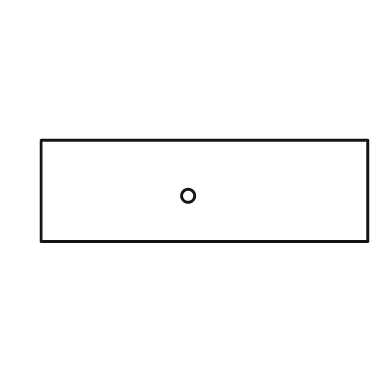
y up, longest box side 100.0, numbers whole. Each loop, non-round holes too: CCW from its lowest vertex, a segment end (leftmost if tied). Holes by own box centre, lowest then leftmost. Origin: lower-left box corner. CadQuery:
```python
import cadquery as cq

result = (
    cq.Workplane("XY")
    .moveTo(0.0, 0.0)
    .lineTo(100.0, 0.0)
    .lineTo(100.0, 31.0)
    .lineTo(0.0, 31.0)
    .close()
    .moveTo(45.0, 14.0)
    .circle(2.0)
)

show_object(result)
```